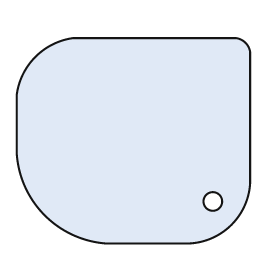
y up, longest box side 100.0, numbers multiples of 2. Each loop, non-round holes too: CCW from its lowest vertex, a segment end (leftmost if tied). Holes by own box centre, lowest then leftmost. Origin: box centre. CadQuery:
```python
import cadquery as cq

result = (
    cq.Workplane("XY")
    .moveTo(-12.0, -44.0)
    .lineTo(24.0, -44.0)
    .threePointArc((42.0, -36.0), (50.0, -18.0))
    .lineTo(50.0, 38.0)
    .threePointArc((48.0, 42.0), (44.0, 44.0))
    .lineTo(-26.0, 44.0)
    .threePointArc((-42.0, 36.0), (-50.0, 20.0))
    .lineTo(-50.0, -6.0)
    .threePointArc((-38.0, -32.0), (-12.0, -44.0))
    .close()
    .moveTo(34.0, -26.0)
    .circle(4.0)
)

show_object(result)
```